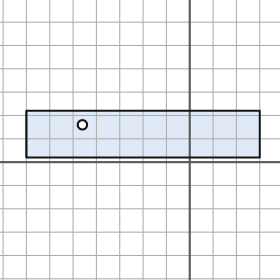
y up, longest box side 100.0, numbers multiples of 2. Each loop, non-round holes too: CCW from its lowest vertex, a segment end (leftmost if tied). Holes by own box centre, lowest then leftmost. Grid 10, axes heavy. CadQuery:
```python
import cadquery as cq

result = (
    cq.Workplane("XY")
    .moveTo(-70.0, 2.0)
    .lineTo(30.0, 2.0)
    .lineTo(30.0, 22.0)
    .lineTo(-70.0, 22.0)
    .close()
    .moveTo(-46.0, 16.0)
    .circle(2.0)
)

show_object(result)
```